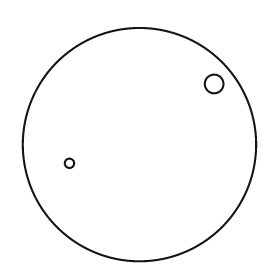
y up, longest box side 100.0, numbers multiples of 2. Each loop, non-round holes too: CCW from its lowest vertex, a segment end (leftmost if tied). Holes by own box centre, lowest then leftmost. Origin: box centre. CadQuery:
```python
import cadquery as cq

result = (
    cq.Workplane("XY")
    .moveTo(0.0, 0.0)
    .circle(50.0)
    .moveTo(-30.0, -8.0)
    .circle(2.0)
    .moveTo(32.0, 26.0)
    .circle(4.0)
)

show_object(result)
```